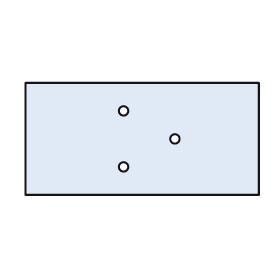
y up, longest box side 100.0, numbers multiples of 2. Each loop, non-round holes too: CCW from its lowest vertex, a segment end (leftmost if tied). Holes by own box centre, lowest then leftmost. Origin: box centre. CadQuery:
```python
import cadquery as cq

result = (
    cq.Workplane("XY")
    .moveTo(-50.0, -24.0)
    .lineTo(50.0, -24.0)
    .lineTo(50.0, 24.0)
    .lineTo(-50.0, 24.0)
    .close()
    .moveTo(-8.0, -12.0)
    .circle(2.0)
    .moveTo(14.0, 0.0)
    .circle(2.0)
    .moveTo(-8.0, 12.0)
    .circle(2.0)
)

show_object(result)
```